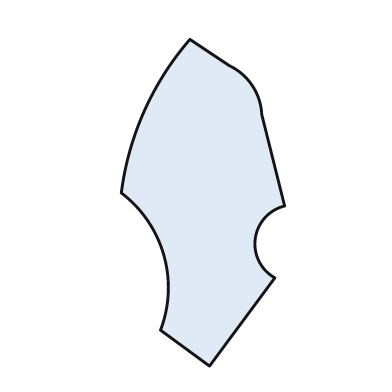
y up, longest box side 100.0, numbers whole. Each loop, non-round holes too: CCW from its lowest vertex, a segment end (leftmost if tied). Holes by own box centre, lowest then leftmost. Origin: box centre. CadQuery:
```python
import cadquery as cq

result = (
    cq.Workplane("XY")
    .moveTo(2.0, -50.0)
    .lineTo(22.0, -23.0)
    .threePointArc((16.0, -11.0), (25.0, -1.0))
    .lineTo(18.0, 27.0)
    .threePointArc((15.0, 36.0), (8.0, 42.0))
    .lineTo(-4.0, 50.0)
    .threePointArc((-18.0, 28.0), (-25.0, 3.0))
    .threePointArc((-12.0, -16.0), (-13.0, -39.0))
    .close()
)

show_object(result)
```